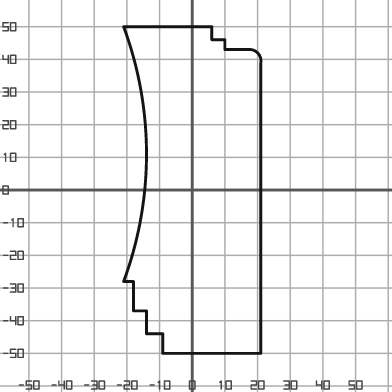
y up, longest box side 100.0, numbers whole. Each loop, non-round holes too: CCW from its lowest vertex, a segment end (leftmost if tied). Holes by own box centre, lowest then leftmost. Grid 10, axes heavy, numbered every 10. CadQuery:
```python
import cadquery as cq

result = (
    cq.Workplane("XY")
    .moveTo(-9.0, -50.0)
    .lineTo(21.0, -50.0)
    .lineTo(21.0, 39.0)
    .threePointArc((20.0, 42.0), (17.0, 43.0))
    .lineTo(10.0, 43.0)
    .lineTo(10.0, 46.0)
    .lineTo(6.0, 46.0)
    .lineTo(6.0, 50.0)
    .lineTo(-21.0, 50.0)
    .threePointArc((-14.0, 11.0), (-21.0, -28.0))
    .lineTo(-18.0, -28.0)
    .lineTo(-18.0, -37.0)
    .lineTo(-14.0, -37.0)
    .lineTo(-14.0, -44.0)
    .lineTo(-9.0, -44.0)
    .close()
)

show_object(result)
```